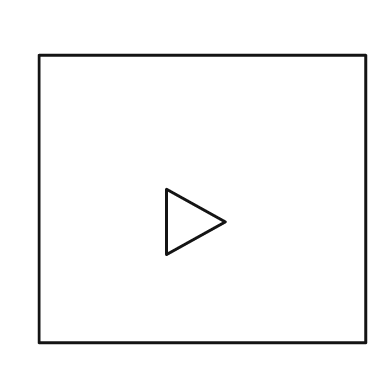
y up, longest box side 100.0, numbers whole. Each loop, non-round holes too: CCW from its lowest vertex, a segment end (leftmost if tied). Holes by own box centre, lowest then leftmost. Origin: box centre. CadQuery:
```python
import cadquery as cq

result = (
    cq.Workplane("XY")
    .moveTo(-50.0, -44.0)
    .lineTo(50.0, -44.0)
    .lineTo(50.0, 44.0)
    .lineTo(-50.0, 44.0)
    .close()
    .moveTo(-11.0, -17.0)
    .lineTo(7.0, -7.0)
    .lineTo(-11.0, 3.0)
    .close()
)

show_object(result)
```